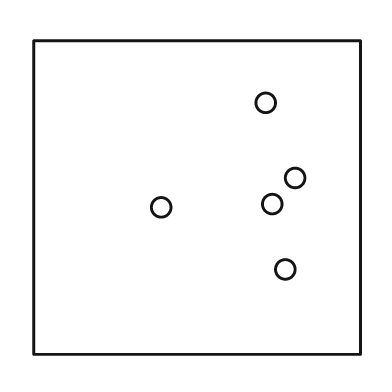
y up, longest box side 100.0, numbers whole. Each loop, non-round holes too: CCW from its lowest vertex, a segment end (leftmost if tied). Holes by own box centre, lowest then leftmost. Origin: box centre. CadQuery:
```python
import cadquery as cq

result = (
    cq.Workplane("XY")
    .moveTo(-50.0, -48.0)
    .lineTo(50.0, -48.0)
    .lineTo(50.0, 48.0)
    .lineTo(-50.0, 48.0)
    .close()
    .moveTo(27.0, -22.0)
    .circle(3.0)
    .moveTo(-11.0, -3.0)
    .circle(3.0)
    .moveTo(23.0, -2.0)
    .circle(3.0)
    .moveTo(30.0, 6.0)
    .circle(3.0)
    .moveTo(21.0, 29.0)
    .circle(3.0)
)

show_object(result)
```